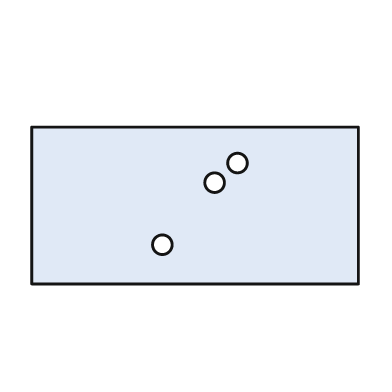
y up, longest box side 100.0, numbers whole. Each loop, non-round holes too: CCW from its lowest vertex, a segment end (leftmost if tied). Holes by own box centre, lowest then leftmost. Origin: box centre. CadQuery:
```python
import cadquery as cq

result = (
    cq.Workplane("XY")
    .moveTo(-50.0, -24.0)
    .lineTo(50.0, -24.0)
    .lineTo(50.0, 24.0)
    .lineTo(-50.0, 24.0)
    .close()
    .moveTo(-10.0, -12.0)
    .circle(3.0)
    .moveTo(6.0, 7.0)
    .circle(3.0)
    .moveTo(13.0, 13.0)
    .circle(3.0)
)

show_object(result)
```